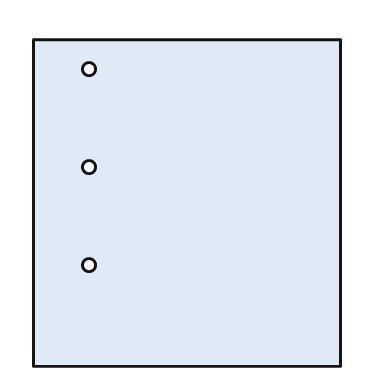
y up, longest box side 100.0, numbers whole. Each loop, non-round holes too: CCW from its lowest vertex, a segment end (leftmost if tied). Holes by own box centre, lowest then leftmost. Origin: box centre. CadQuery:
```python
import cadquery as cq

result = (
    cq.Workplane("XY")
    .moveTo(-47.0, -50.0)
    .lineTo(47.0, -50.0)
    .lineTo(47.0, 50.0)
    .lineTo(-47.0, 50.0)
    .close()
    .moveTo(-30.0, -19.0)
    .circle(2.0)
    .moveTo(-30.0, 11.0)
    .circle(2.0)
    .moveTo(-30.0, 41.0)
    .circle(2.0)
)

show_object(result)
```